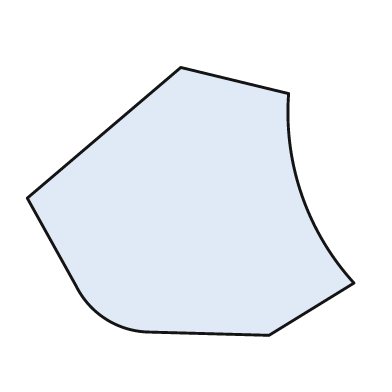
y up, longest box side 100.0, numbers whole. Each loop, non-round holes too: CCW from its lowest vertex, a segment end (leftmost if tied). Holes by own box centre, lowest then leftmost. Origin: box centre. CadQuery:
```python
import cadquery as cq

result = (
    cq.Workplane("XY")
    .moveTo(24.0, -41.0)
    .lineTo(50.0, -25.0)
    .threePointArc((34.0, 2.0), (30.0, 33.0))
    .lineTo(-3.0, 41.0)
    .lineTo(-50.0, 1.0)
    .lineTo(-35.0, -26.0)
    .threePointArc((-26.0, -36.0), (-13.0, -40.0))
    .close()
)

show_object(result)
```